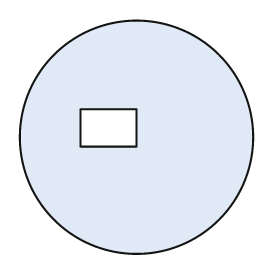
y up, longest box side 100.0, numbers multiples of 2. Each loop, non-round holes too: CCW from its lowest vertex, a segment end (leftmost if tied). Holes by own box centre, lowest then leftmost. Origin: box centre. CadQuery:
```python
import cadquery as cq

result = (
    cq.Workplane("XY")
    .moveTo(0.0, 0.0)
    .circle(50.0)
    .moveTo(-24.0, -4.0)
    .lineTo(0.0, -4.0)
    .lineTo(0.0, 12.0)
    .lineTo(-24.0, 12.0)
    .close()
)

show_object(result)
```